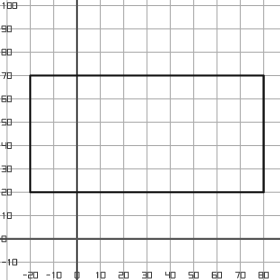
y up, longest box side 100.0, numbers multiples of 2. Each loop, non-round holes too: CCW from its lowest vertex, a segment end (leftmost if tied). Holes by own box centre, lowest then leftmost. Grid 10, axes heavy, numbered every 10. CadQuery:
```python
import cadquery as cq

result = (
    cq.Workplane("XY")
    .moveTo(-20.0, 20.0)
    .lineTo(80.0, 20.0)
    .lineTo(80.0, 70.0)
    .lineTo(-20.0, 70.0)
    .close()
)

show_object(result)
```